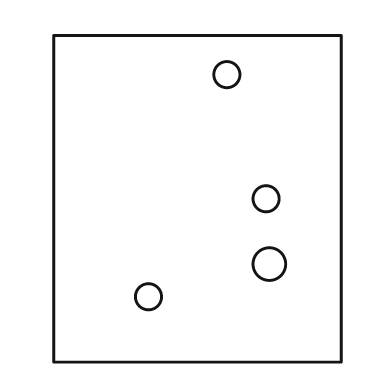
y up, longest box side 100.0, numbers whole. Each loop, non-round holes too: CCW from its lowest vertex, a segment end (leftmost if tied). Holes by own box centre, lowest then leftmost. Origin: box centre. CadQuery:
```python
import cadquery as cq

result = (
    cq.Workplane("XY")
    .moveTo(-44.0, -50.0)
    .lineTo(44.0, -50.0)
    .lineTo(44.0, 50.0)
    .lineTo(-44.0, 50.0)
    .close()
    .moveTo(-15.0, -30.0)
    .circle(4.0)
    .moveTo(22.0, -20.0)
    .circle(5.0)
    .moveTo(21.0, 0.0)
    .circle(4.0)
    .moveTo(9.0, 38.0)
    .circle(4.0)
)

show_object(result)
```